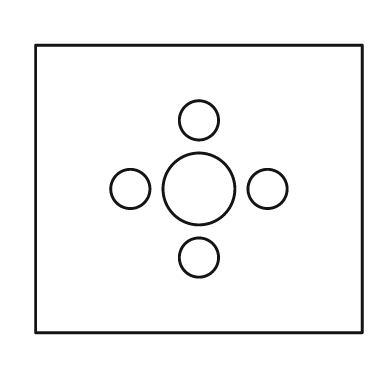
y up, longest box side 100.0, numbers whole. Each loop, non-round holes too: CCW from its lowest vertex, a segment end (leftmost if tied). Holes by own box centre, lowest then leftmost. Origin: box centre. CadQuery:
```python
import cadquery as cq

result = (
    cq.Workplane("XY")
    .moveTo(-50.0, -44.0)
    .lineTo(50.0, -44.0)
    .lineTo(50.0, 44.0)
    .lineTo(-50.0, 44.0)
    .close()
    .moveTo(0.0, -21.0)
    .circle(6.0)
    .moveTo(-21.0, 0.0)
    .circle(6.0)
    .moveTo(0.0, 0.0)
    .circle(11.0)
    .moveTo(21.0, 0.0)
    .circle(6.0)
    .moveTo(0.0, 21.0)
    .circle(6.0)
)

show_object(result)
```